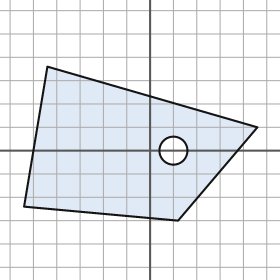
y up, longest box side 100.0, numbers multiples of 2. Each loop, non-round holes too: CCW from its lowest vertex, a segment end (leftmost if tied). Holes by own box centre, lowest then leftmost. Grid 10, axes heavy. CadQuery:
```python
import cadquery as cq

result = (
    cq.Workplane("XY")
    .moveTo(12.0, -30.0)
    .lineTo(46.0, 10.0)
    .lineTo(-44.0, 36.0)
    .lineTo(-54.0, -24.0)
    .close()
    .moveTo(10.0, 0.0)
    .circle(6.0)
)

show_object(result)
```